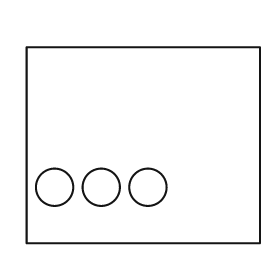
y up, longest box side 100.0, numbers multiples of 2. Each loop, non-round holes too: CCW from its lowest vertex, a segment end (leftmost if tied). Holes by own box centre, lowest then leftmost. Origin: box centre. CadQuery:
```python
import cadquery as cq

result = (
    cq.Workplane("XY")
    .moveTo(-50.0, -42.0)
    .lineTo(50.0, -42.0)
    .lineTo(50.0, 42.0)
    .lineTo(-50.0, 42.0)
    .close()
    .moveTo(-38.0, -18.0)
    .circle(8.0)
    .moveTo(-18.0, -18.0)
    .circle(8.0)
    .moveTo(2.0, -18.0)
    .circle(8.0)
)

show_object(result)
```